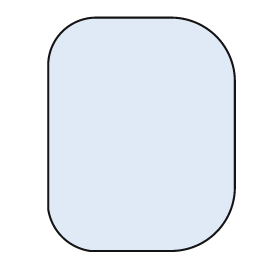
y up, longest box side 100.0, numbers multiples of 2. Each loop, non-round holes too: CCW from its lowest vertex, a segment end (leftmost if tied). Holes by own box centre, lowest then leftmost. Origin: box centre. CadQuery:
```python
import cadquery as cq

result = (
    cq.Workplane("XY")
    .moveTo(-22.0, -50.0)
    .lineTo(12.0, -50.0)
    .threePointArc((32.0, -42.0), (40.0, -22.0))
    .lineTo(40.0, 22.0)
    .threePointArc((32.0, 42.0), (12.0, 50.0))
    .lineTo(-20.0, 50.0)
    .threePointArc((-34.0, 44.0), (-40.0, 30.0))
    .lineTo(-40.0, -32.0)
    .threePointArc((-34.0, -44.0), (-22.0, -50.0))
    .close()
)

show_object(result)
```